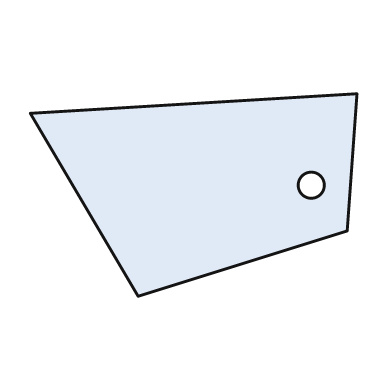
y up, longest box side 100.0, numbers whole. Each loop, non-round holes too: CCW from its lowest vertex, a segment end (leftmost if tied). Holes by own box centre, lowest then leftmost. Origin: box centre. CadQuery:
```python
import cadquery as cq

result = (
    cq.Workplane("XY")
    .moveTo(-17.0, -31.0)
    .lineTo(47.0, -11.0)
    .lineTo(50.0, 31.0)
    .lineTo(-50.0, 25.0)
    .close()
    .moveTo(36.0, 3.0)
    .circle(4.0)
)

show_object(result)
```